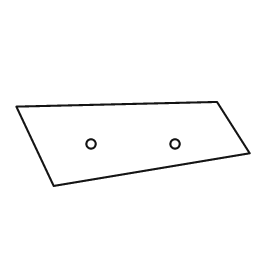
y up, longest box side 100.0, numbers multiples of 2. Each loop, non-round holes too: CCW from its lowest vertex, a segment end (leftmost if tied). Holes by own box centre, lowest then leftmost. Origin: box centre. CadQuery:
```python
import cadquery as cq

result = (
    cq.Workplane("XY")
    .moveTo(-34.0, -18.0)
    .lineTo(50.0, -4.0)
    .lineTo(36.0, 18.0)
    .lineTo(-50.0, 16.0)
    .close()
    .moveTo(-18.0, 0.0)
    .circle(2.0)
    .moveTo(18.0, 0.0)
    .circle(2.0)
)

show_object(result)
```